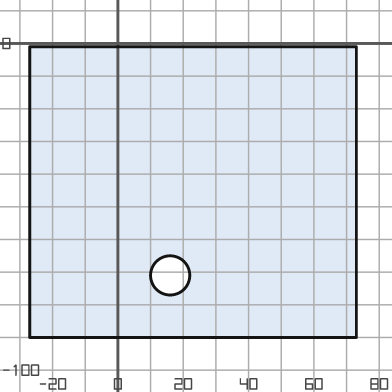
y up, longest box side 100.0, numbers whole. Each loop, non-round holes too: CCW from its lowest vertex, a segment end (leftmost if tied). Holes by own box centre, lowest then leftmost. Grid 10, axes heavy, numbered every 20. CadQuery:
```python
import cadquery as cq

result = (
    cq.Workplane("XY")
    .moveTo(-27.0, -90.0)
    .lineTo(73.0, -90.0)
    .lineTo(73.0, -1.0)
    .lineTo(-27.0, -1.0)
    .close()
    .moveTo(16.0, -71.0)
    .circle(6.0)
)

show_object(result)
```